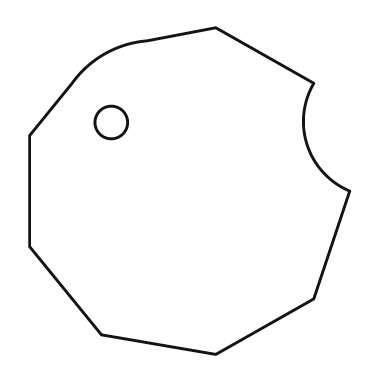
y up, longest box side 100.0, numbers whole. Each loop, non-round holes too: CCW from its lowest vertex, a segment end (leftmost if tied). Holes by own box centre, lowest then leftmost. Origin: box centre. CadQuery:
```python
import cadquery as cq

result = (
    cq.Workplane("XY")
    .moveTo(8.0, -50.0)
    .lineTo(38.0, -33.0)
    .lineTo(49.0, 0.0)
    .threePointArc((36.0, 14.0), (38.0, 33.0))
    .lineTo(8.0, 50.0)
    .lineTo(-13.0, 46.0)
    .threePointArc((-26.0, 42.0), (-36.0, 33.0))
    .lineTo(-49.0, 17.0)
    .lineTo(-49.0, -17.0)
    .lineTo(-27.0, -44.0)
    .close()
    .moveTo(-24.0, 21.0)
    .circle(5.0)
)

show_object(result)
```